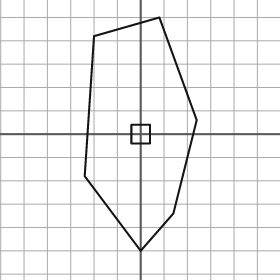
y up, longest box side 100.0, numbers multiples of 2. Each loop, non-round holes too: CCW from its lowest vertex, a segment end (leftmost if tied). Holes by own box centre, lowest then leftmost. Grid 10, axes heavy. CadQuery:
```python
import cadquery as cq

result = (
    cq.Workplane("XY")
    .moveTo(0.0, -50.0)
    .lineTo(14.0, -34.0)
    .lineTo(24.0, 6.0)
    .lineTo(8.0, 50.0)
    .lineTo(-20.0, 42.0)
    .lineTo(-24.0, -18.0)
    .close()
    .moveTo(-4.0, -4.0)
    .lineTo(4.0, -4.0)
    .lineTo(4.0, 4.0)
    .lineTo(-4.0, 4.0)
    .close()
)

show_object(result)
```